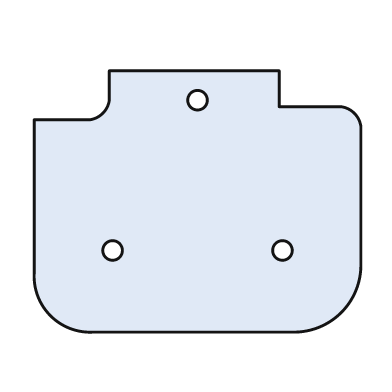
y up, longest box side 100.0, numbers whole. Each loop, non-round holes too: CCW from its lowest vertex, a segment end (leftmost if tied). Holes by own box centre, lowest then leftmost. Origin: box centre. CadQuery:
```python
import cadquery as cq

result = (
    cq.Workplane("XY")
    .moveTo(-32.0, -40.0)
    .lineTo(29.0, -40.0)
    .threePointArc((44.0, -34.0), (50.0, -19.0))
    .lineTo(50.0, 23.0)
    .threePointArc((48.0, 27.0), (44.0, 29.0))
    .lineTo(25.0, 29.0)
    .lineTo(25.0, 40.0)
    .lineTo(-27.0, 40.0)
    .lineTo(-27.0, 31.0)
    .threePointArc((-29.0, 27.0), (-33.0, 25.0))
    .lineTo(-50.0, 25.0)
    .lineTo(-50.0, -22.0)
    .threePointArc((-45.0, -35.0), (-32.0, -40.0))
    .close()
    .moveTo(-26.0, -15.0)
    .circle(3.0)
    .moveTo(26.0, -15.0)
    .circle(3.0)
    .moveTo(0.0, 31.0)
    .circle(3.0)
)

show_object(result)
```